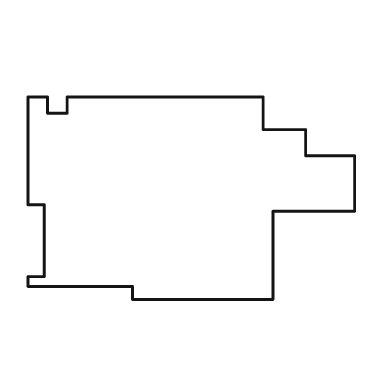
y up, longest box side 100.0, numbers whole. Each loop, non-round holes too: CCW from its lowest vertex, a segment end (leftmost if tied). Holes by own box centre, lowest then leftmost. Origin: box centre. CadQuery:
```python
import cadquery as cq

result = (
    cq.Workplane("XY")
    .moveTo(-18.0, -31.0)
    .lineTo(25.0, -31.0)
    .lineTo(25.0, -4.0)
    .lineTo(50.0, -4.0)
    .lineTo(50.0, 13.0)
    .lineTo(35.0, 13.0)
    .lineTo(35.0, 21.0)
    .lineTo(22.0, 21.0)
    .lineTo(22.0, 31.0)
    .lineTo(-38.0, 31.0)
    .lineTo(-38.0, 26.0)
    .lineTo(-44.0, 26.0)
    .lineTo(-44.0, 31.0)
    .lineTo(-50.0, 31.0)
    .lineTo(-50.0, -2.0)
    .lineTo(-45.0, -2.0)
    .lineTo(-45.0, -24.0)
    .lineTo(-50.0, -24.0)
    .lineTo(-50.0, -27.0)
    .lineTo(-18.0, -27.0)
    .close()
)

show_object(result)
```